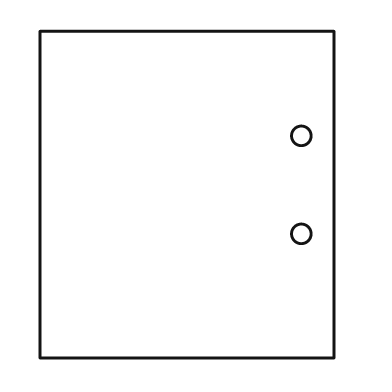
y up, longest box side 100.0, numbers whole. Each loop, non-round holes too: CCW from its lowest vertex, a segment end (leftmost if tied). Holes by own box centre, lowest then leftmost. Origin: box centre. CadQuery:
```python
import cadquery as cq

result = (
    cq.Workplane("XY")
    .moveTo(-45.0, -50.0)
    .lineTo(45.0, -50.0)
    .lineTo(45.0, 50.0)
    .lineTo(-45.0, 50.0)
    .close()
    .moveTo(35.0, -12.0)
    .circle(3.0)
    .moveTo(35.0, 18.0)
    .circle(3.0)
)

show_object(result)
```